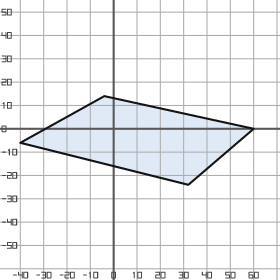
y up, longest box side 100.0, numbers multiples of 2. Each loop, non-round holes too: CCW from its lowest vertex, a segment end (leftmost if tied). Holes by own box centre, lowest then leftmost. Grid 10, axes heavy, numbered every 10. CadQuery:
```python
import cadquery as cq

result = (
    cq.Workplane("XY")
    .moveTo(32.0, -24.0)
    .lineTo(60.0, 0.0)
    .lineTo(-4.0, 14.0)
    .lineTo(-40.0, -6.0)
    .close()
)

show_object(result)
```